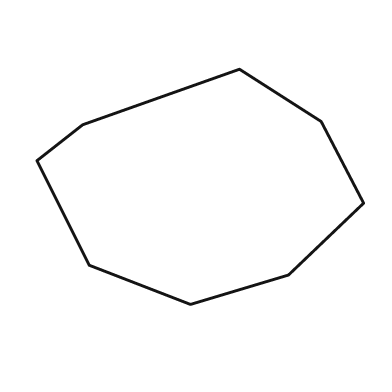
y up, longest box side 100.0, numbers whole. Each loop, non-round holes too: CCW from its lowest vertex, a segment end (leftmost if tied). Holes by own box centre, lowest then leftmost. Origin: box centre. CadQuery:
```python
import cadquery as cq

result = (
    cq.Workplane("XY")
    .moveTo(-3.0, -36.0)
    .lineTo(27.0, -27.0)
    .lineTo(50.0, -5.0)
    .lineTo(37.0, 20.0)
    .lineTo(12.0, 36.0)
    .lineTo(-36.0, 19.0)
    .lineTo(-50.0, 8.0)
    .lineTo(-34.0, -24.0)
    .close()
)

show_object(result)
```